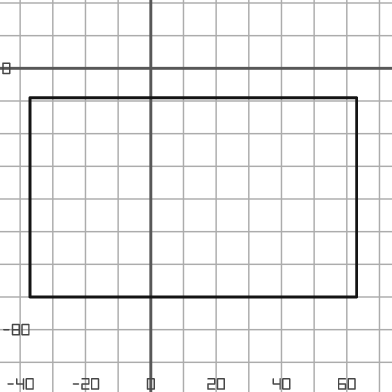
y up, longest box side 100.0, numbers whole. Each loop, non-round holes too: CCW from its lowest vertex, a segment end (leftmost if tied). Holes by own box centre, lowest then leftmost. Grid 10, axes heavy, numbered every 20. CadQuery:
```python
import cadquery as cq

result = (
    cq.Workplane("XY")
    .moveTo(-37.0, -70.0)
    .lineTo(63.0, -70.0)
    .lineTo(63.0, -9.0)
    .lineTo(-37.0, -9.0)
    .close()
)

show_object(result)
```